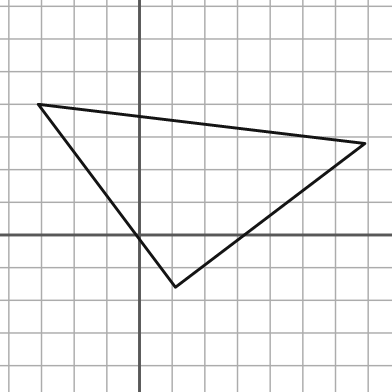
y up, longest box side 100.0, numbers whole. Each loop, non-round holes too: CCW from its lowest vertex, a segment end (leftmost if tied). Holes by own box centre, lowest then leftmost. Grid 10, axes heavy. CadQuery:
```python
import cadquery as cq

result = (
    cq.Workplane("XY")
    .moveTo(11.0, -16.0)
    .lineTo(69.0, 28.0)
    .lineTo(-31.0, 40.0)
    .close()
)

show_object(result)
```